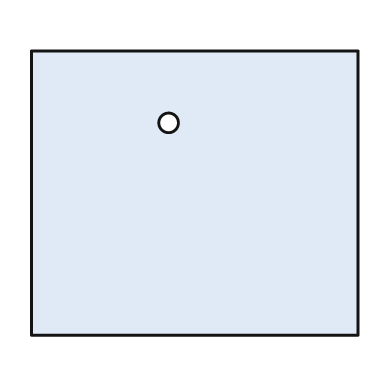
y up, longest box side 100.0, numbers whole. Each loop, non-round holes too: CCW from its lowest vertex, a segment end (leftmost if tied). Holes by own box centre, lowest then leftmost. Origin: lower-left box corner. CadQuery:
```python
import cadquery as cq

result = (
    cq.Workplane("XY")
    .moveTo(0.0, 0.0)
    .lineTo(100.0, 0.0)
    .lineTo(100.0, 87.0)
    .lineTo(0.0, 87.0)
    .close()
    .moveTo(42.0, 65.0)
    .circle(3.0)
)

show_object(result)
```